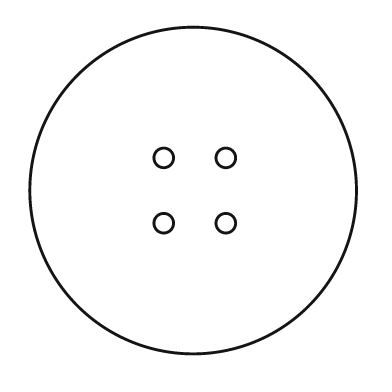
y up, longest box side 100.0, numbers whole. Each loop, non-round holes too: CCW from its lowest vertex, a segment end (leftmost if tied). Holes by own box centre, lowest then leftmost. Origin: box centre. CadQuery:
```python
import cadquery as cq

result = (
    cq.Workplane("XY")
    .moveTo(0.0, 0.0)
    .circle(50.0)
    .moveTo(-9.0, -10.0)
    .circle(3.0)
    .moveTo(10.0, -10.0)
    .circle(3.0)
    .moveTo(-9.0, 10.0)
    .circle(3.0)
    .moveTo(10.0, 10.0)
    .circle(3.0)
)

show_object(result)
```